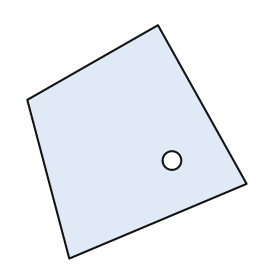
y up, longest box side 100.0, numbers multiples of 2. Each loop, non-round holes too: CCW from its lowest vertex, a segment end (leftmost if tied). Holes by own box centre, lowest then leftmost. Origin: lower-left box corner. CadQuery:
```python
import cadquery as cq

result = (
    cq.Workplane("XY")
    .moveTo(18.0, 0.0)
    .lineTo(94.0, 32.0)
    .lineTo(56.0, 100.0)
    .lineTo(0.0, 68.0)
    .close()
    .moveTo(62.0, 42.0)
    .circle(4.0)
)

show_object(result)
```